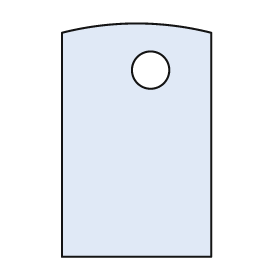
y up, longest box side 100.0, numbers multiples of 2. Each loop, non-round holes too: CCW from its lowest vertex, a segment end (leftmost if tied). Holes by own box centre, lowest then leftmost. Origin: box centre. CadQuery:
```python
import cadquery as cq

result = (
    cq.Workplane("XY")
    .moveTo(-32.0, -50.0)
    .lineTo(32.0, -50.0)
    .lineTo(32.0, 46.0)
    .threePointArc((0.0, 50.0), (-32.0, 46.0))
    .close()
    .moveTo(6.0, 30.0)
    .circle(8.0)
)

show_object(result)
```